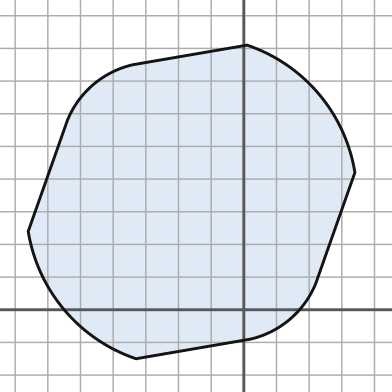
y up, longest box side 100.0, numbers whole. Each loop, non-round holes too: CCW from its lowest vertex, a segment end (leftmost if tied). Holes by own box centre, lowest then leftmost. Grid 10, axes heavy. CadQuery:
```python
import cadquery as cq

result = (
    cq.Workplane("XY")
    .moveTo(-33.0, -15.0)
    .lineTo(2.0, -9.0)
    .threePointArc((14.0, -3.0), (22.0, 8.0))
    .lineTo(34.0, 42.0)
    .threePointArc((23.0, 66.0), (1.0, 81.0))
    .lineTo(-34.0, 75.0)
    .threePointArc((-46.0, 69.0), (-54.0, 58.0))
    .lineTo(-66.0, 24.0)
    .threePointArc((-55.0, 0.0), (-33.0, -15.0))
    .close()
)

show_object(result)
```